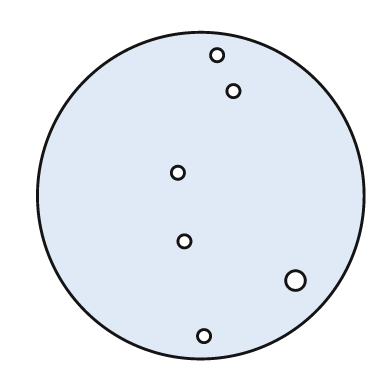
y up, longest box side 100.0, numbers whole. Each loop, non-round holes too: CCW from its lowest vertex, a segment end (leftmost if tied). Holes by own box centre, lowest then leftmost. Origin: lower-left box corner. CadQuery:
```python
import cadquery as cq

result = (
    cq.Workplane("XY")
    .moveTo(50.0, 50.0)
    .circle(50.0)
    .moveTo(51.0, 7.0)
    .circle(2.0)
    .moveTo(79.0, 24.0)
    .circle(3.0)
    .moveTo(45.0, 36.0)
    .circle(2.0)
    .moveTo(43.0, 57.0)
    .circle(2.0)
    .moveTo(60.0, 82.0)
    .circle(2.0)
    .moveTo(55.0, 93.0)
    .circle(2.0)
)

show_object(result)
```